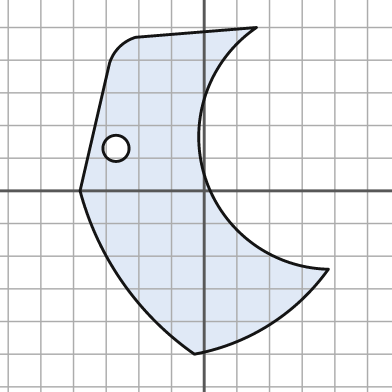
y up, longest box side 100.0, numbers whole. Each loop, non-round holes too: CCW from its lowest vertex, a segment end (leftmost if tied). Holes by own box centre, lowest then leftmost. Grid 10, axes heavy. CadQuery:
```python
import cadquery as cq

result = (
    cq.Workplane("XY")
    .moveTo(-3.0, -50.0)
    .threePointArc((20.0, -41.0), (38.0, -24.0))
    .threePointArc((0.0, 5.0), (16.0, 50.0))
    .lineTo(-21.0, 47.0)
    .threePointArc((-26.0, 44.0), (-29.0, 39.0))
    .lineTo(-38.0, 0.0)
    .threePointArc((-25.0, -28.0), (-3.0, -50.0))
    .close()
    .moveTo(-27.0, 13.0)
    .circle(4.0)
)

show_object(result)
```